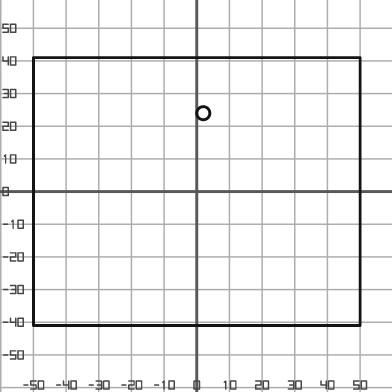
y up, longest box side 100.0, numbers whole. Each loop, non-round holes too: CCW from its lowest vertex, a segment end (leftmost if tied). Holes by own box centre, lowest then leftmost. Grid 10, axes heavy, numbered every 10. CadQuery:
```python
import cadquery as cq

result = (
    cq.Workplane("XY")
    .moveTo(-50.0, -41.0)
    .lineTo(50.0, -41.0)
    .lineTo(50.0, 41.0)
    .lineTo(-50.0, 41.0)
    .close()
    .moveTo(2.0, 24.0)
    .circle(2.0)
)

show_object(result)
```